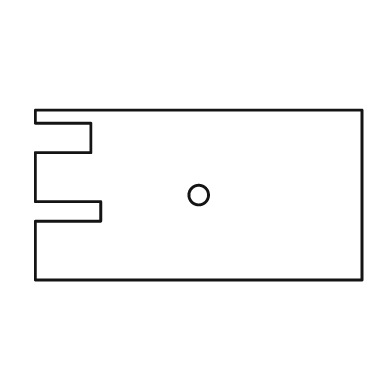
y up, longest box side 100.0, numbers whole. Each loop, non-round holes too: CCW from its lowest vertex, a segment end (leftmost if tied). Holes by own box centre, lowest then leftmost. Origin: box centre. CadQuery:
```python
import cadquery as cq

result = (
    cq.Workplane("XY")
    .moveTo(-50.0, -26.0)
    .lineTo(50.0, -26.0)
    .lineTo(50.0, 26.0)
    .lineTo(-50.0, 26.0)
    .lineTo(-50.0, 22.0)
    .lineTo(-33.0, 22.0)
    .lineTo(-33.0, 13.0)
    .lineTo(-50.0, 13.0)
    .lineTo(-50.0, -2.0)
    .lineTo(-30.0, -2.0)
    .lineTo(-30.0, -8.0)
    .lineTo(-50.0, -8.0)
    .close()
    .moveTo(0.0, 0.0)
    .circle(3.0)
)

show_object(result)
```